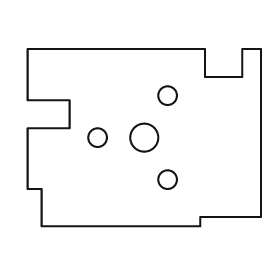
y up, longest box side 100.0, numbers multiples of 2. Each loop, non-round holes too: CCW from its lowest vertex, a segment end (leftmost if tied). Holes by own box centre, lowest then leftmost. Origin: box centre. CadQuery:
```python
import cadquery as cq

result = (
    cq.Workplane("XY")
    .moveTo(-44.0, -38.0)
    .lineTo(24.0, -38.0)
    .lineTo(24.0, -34.0)
    .lineTo(50.0, -34.0)
    .lineTo(50.0, 38.0)
    .lineTo(42.0, 38.0)
    .lineTo(42.0, 26.0)
    .lineTo(26.0, 26.0)
    .lineTo(26.0, 38.0)
    .lineTo(-50.0, 38.0)
    .lineTo(-50.0, 16.0)
    .lineTo(-32.0, 16.0)
    .lineTo(-32.0, 4.0)
    .lineTo(-50.0, 4.0)
    .lineTo(-50.0, -22.0)
    .lineTo(-44.0, -22.0)
    .close()
    .moveTo(10.0, -18.0)
    .circle(4.0)
    .moveTo(-20.0, 0.0)
    .circle(4.0)
    .moveTo(0.0, 0.0)
    .circle(6.0)
    .moveTo(10.0, 18.0)
    .circle(4.0)
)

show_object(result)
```